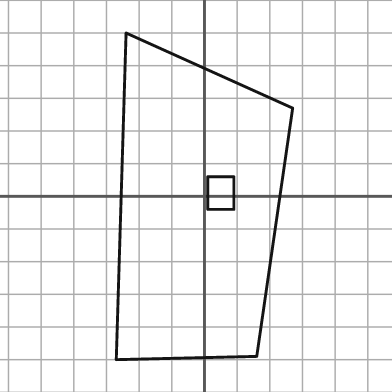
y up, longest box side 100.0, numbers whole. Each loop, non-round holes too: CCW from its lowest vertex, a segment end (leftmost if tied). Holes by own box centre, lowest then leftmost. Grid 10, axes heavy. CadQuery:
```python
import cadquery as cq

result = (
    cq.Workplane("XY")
    .moveTo(-27.0, -50.0)
    .lineTo(16.0, -49.0)
    .lineTo(27.0, 27.0)
    .lineTo(-24.0, 50.0)
    .close()
    .moveTo(1.0, -4.0)
    .lineTo(9.0, -4.0)
    .lineTo(9.0, 6.0)
    .lineTo(1.0, 6.0)
    .close()
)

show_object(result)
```